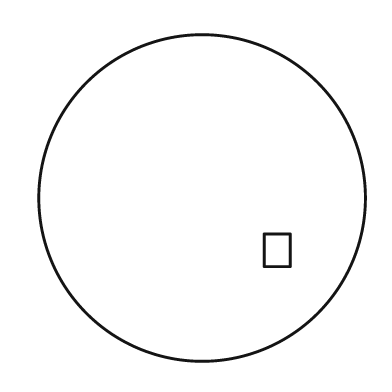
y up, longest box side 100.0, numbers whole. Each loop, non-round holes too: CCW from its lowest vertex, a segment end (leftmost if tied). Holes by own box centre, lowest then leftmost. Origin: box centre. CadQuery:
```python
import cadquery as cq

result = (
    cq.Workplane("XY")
    .moveTo(0.0, 0.0)
    .circle(50.0)
    .moveTo(19.0, -21.0)
    .lineTo(27.0, -21.0)
    .lineTo(27.0, -11.0)
    .lineTo(19.0, -11.0)
    .close()
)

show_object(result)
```